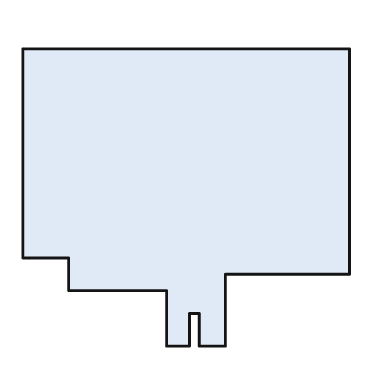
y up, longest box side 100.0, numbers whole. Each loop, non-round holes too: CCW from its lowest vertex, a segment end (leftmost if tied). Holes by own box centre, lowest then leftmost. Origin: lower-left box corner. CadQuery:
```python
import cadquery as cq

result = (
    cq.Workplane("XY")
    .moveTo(44.0, 0.0)
    .lineTo(51.0, 0.0)
    .lineTo(51.0, 10.0)
    .lineTo(54.0, 10.0)
    .lineTo(54.0, 0.0)
    .lineTo(62.0, 0.0)
    .lineTo(62.0, 22.0)
    .lineTo(100.0, 22.0)
    .lineTo(100.0, 91.0)
    .lineTo(0.0, 91.0)
    .lineTo(0.0, 27.0)
    .lineTo(14.0, 27.0)
    .lineTo(14.0, 17.0)
    .lineTo(44.0, 17.0)
    .close()
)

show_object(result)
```